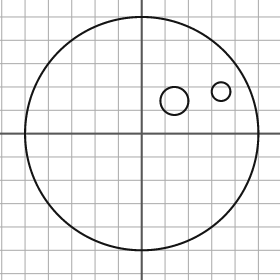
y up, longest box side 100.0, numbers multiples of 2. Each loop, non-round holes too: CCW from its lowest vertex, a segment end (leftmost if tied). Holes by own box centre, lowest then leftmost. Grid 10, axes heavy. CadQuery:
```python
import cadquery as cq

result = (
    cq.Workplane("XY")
    .moveTo(0.0, 0.0)
    .circle(50.0)
    .moveTo(14.0, 14.0)
    .circle(6.0)
    .moveTo(34.0, 18.0)
    .circle(4.0)
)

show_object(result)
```